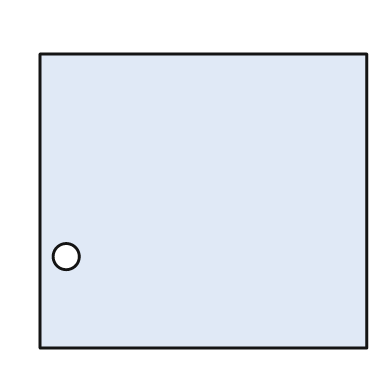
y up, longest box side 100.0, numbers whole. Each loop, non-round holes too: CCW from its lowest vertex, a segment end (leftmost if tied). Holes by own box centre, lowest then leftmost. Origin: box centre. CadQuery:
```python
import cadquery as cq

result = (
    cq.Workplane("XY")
    .moveTo(-50.0, -45.0)
    .lineTo(50.0, -45.0)
    .lineTo(50.0, 45.0)
    .lineTo(-50.0, 45.0)
    .close()
    .moveTo(-42.0, -17.0)
    .circle(4.0)
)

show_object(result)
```